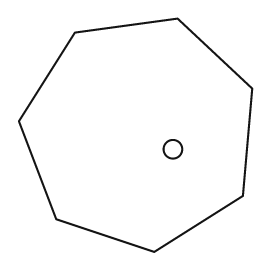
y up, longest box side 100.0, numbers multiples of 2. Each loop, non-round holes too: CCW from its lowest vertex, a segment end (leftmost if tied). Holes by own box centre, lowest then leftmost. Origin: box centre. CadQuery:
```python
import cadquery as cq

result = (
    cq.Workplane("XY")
    .moveTo(8.0, -50.0)
    .lineTo(46.0, -26.0)
    .lineTo(50.0, 20.0)
    .lineTo(18.0, 50.0)
    .lineTo(-26.0, 44.0)
    .lineTo(-50.0, 6.0)
    .lineTo(-34.0, -36.0)
    .close()
    .moveTo(16.0, -6.0)
    .circle(4.0)
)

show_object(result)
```